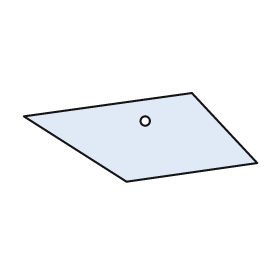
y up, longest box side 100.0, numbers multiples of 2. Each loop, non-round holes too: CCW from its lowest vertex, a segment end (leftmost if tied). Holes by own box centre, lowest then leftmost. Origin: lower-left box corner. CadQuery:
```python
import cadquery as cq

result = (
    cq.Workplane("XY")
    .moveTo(44.0, 0.0)
    .lineTo(100.0, 8.0)
    .lineTo(72.0, 38.0)
    .lineTo(0.0, 28.0)
    .close()
    .moveTo(52.0, 26.0)
    .circle(2.0)
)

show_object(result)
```